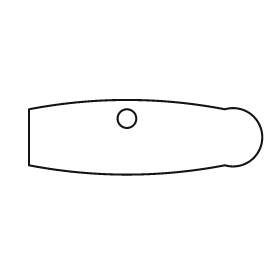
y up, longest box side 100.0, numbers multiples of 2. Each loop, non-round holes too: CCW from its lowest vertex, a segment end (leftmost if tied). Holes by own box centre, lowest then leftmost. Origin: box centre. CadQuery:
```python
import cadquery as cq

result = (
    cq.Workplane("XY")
    .moveTo(-50.0, -12.0)
    .threePointArc((-8.0, -16.0), (34.0, -12.0))
    .threePointArc((50.0, 0.0), (34.0, 12.0))
    .threePointArc((-8.0, 16.0), (-50.0, 12.0))
    .close()
    .moveTo(-8.0, 8.0)
    .circle(4.0)
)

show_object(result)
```